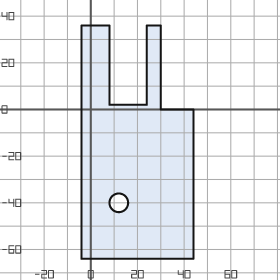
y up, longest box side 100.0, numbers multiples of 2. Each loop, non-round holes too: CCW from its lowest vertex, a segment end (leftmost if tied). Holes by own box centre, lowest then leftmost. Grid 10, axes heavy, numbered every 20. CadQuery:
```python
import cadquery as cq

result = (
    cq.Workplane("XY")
    .moveTo(-4.0, -64.0)
    .lineTo(44.0, -64.0)
    .lineTo(44.0, 0.0)
    .lineTo(30.0, 0.0)
    .lineTo(30.0, 36.0)
    .lineTo(24.0, 36.0)
    .lineTo(24.0, 2.0)
    .lineTo(8.0, 2.0)
    .lineTo(8.0, 36.0)
    .lineTo(-4.0, 36.0)
    .close()
    .moveTo(12.0, -40.0)
    .circle(4.0)
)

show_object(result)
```